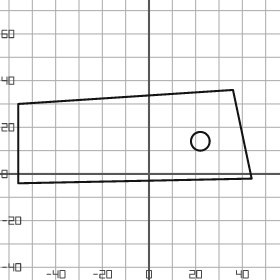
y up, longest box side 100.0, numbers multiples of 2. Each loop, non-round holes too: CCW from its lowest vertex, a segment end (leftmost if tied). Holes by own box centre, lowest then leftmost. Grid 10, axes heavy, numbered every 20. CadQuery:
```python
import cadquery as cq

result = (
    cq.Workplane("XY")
    .moveTo(-56.0, -4.0)
    .lineTo(44.0, -2.0)
    .lineTo(36.0, 36.0)
    .lineTo(-56.0, 30.0)
    .close()
    .moveTo(22.0, 14.0)
    .circle(4.0)
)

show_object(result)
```